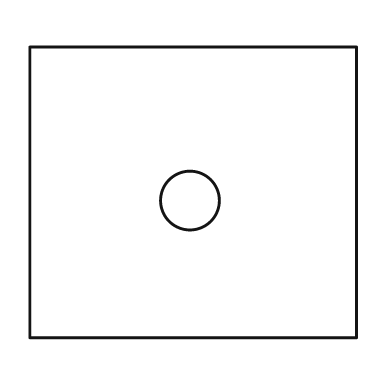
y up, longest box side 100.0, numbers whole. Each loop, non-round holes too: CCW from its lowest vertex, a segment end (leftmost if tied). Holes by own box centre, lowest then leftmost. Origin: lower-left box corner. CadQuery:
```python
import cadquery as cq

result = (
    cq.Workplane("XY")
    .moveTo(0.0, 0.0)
    .lineTo(100.0, 0.0)
    .lineTo(100.0, 89.0)
    .lineTo(0.0, 89.0)
    .close()
    .moveTo(49.0, 42.0)
    .circle(9.0)
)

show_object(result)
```